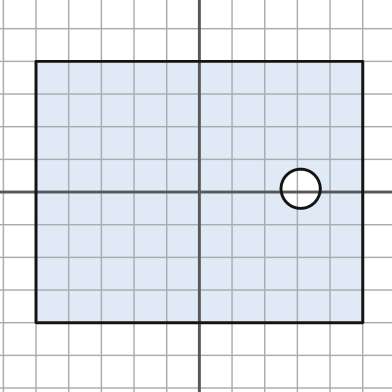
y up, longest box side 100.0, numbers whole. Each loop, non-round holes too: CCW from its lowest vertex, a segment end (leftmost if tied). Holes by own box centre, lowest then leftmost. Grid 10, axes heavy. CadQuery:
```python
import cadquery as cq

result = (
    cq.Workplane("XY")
    .moveTo(-50.0, -40.0)
    .lineTo(50.0, -40.0)
    .lineTo(50.0, 40.0)
    .lineTo(-50.0, 40.0)
    .close()
    .moveTo(31.0, 1.0)
    .circle(6.0)
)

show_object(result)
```